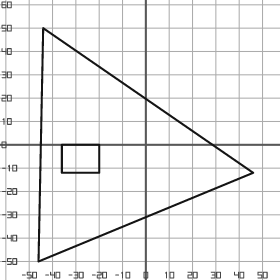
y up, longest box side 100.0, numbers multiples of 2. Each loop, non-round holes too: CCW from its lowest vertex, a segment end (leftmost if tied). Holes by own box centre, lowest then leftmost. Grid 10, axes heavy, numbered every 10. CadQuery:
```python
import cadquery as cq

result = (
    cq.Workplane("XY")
    .moveTo(-46.0, -50.0)
    .lineTo(46.0, -12.0)
    .lineTo(-44.0, 50.0)
    .close()
    .moveTo(-36.0, -12.0)
    .lineTo(-20.0, -12.0)
    .lineTo(-20.0, 0.0)
    .lineTo(-36.0, 0.0)
    .close()
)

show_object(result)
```